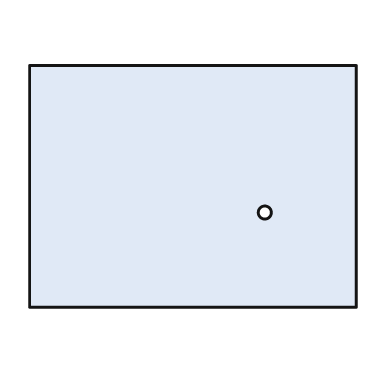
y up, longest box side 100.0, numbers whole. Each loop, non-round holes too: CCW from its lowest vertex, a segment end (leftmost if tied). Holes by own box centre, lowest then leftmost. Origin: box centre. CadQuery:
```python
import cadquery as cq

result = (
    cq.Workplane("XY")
    .moveTo(-50.0, -37.0)
    .lineTo(50.0, -37.0)
    .lineTo(50.0, 37.0)
    .lineTo(-50.0, 37.0)
    .close()
    .moveTo(22.0, -8.0)
    .circle(2.0)
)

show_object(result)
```